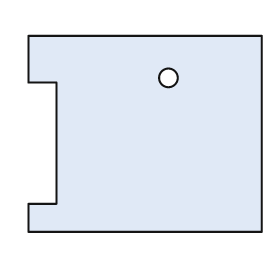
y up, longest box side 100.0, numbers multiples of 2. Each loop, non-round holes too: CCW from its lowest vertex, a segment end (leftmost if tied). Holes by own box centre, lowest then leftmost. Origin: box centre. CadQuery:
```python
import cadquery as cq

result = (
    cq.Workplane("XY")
    .moveTo(-50.0, -42.0)
    .lineTo(50.0, -42.0)
    .lineTo(50.0, 42.0)
    .lineTo(-50.0, 42.0)
    .lineTo(-50.0, 22.0)
    .lineTo(-38.0, 22.0)
    .lineTo(-38.0, -30.0)
    .lineTo(-50.0, -30.0)
    .close()
    .moveTo(10.0, 24.0)
    .circle(4.0)
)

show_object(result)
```